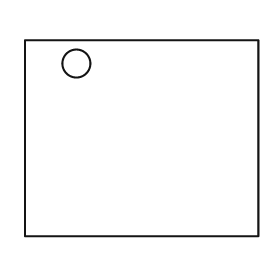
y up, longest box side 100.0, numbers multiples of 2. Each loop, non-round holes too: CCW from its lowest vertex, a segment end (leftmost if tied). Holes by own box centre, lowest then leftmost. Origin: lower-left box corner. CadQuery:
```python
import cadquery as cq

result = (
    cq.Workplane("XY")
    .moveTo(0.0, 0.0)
    .lineTo(100.0, 0.0)
    .lineTo(100.0, 84.0)
    .lineTo(0.0, 84.0)
    .close()
    .moveTo(22.0, 74.0)
    .circle(6.0)
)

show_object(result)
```